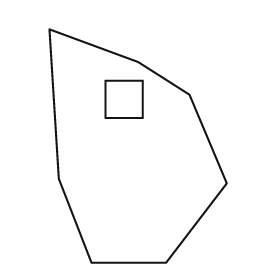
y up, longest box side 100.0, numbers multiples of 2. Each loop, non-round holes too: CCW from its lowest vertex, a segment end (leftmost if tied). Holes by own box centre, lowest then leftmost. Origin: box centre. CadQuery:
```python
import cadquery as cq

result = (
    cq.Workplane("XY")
    .moveTo(-20.0, -50.0)
    .lineTo(12.0, -50.0)
    .lineTo(38.0, -16.0)
    .lineTo(22.0, 22.0)
    .lineTo(0.0, 36.0)
    .lineTo(-38.0, 50.0)
    .lineTo(-34.0, -14.0)
    .close()
    .moveTo(-14.0, 12.0)
    .lineTo(2.0, 12.0)
    .lineTo(2.0, 28.0)
    .lineTo(-14.0, 28.0)
    .close()
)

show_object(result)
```